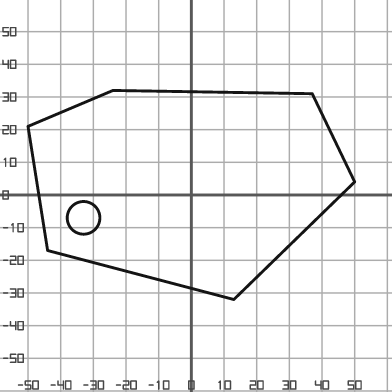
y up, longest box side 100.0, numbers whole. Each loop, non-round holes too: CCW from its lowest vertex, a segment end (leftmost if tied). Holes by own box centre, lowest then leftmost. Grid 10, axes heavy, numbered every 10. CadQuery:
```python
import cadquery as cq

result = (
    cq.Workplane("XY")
    .moveTo(13.0, -32.0)
    .lineTo(50.0, 4.0)
    .lineTo(37.0, 31.0)
    .lineTo(-24.0, 32.0)
    .lineTo(-50.0, 21.0)
    .lineTo(-44.0, -17.0)
    .close()
    .moveTo(-33.0, -7.0)
    .circle(5.0)
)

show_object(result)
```